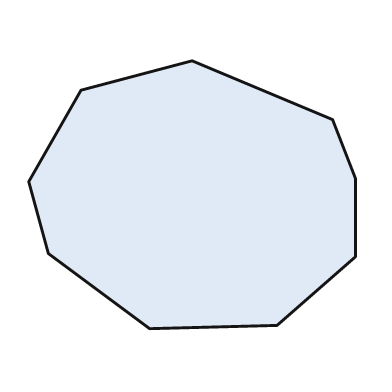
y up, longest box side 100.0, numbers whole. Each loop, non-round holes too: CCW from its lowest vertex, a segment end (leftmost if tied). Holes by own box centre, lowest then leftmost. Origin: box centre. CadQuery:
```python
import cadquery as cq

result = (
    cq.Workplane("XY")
    .moveTo(-13.0, -41.0)
    .lineTo(26.0, -40.0)
    .lineTo(50.0, -19.0)
    .lineTo(50.0, 5.0)
    .lineTo(43.0, 23.0)
    .lineTo(0.0, 41.0)
    .lineTo(-34.0, 32.0)
    .lineTo(-50.0, 4.0)
    .lineTo(-44.0, -18.0)
    .close()
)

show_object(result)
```